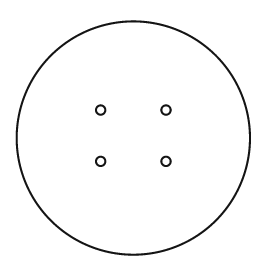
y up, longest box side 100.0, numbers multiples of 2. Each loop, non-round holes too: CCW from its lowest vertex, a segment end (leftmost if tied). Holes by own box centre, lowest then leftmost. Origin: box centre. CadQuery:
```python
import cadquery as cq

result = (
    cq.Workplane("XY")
    .moveTo(0.0, 0.0)
    .circle(50.0)
    .moveTo(-14.0, -10.0)
    .circle(2.0)
    .moveTo(14.0, -10.0)
    .circle(2.0)
    .moveTo(-14.0, 12.0)
    .circle(2.0)
    .moveTo(14.0, 12.0)
    .circle(2.0)
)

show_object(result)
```